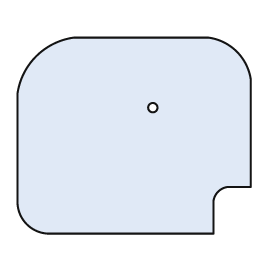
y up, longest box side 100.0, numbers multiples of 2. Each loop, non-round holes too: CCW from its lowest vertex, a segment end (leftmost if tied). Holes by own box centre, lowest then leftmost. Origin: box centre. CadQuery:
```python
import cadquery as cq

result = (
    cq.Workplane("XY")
    .moveTo(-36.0, -42.0)
    .lineTo(34.0, -42.0)
    .lineTo(34.0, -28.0)
    .threePointArc((36.0, -24.0), (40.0, -22.0))
    .lineTo(50.0, -22.0)
    .lineTo(50.0, 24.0)
    .threePointArc((44.0, 36.0), (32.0, 42.0))
    .lineTo(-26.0, 42.0)
    .threePointArc((-42.0, 34.0), (-50.0, 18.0))
    .lineTo(-50.0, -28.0)
    .threePointArc((-46.0, -38.0), (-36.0, -42.0))
    .close()
    .moveTo(8.0, 12.0)
    .circle(2.0)
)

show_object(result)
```